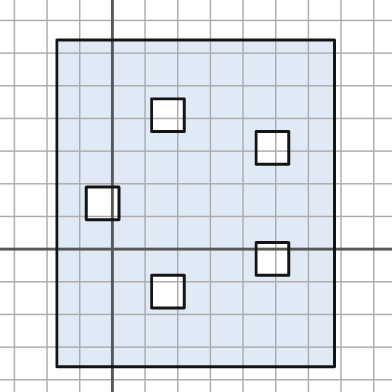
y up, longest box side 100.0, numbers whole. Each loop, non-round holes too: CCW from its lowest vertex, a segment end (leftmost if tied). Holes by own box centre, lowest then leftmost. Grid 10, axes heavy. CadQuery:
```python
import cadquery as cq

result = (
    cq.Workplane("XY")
    .moveTo(-17.0, -36.0)
    .lineTo(68.0, -36.0)
    .lineTo(68.0, 64.0)
    .lineTo(-17.0, 64.0)
    .close()
    .moveTo(12.0, -18.0)
    .lineTo(22.0, -18.0)
    .lineTo(22.0, -8.0)
    .lineTo(12.0, -8.0)
    .close()
    .moveTo(44.0, -8.0)
    .lineTo(54.0, -8.0)
    .lineTo(54.0, 2.0)
    .lineTo(44.0, 2.0)
    .close()
    .moveTo(-8.0, 9.0)
    .lineTo(2.0, 9.0)
    .lineTo(2.0, 19.0)
    .lineTo(-8.0, 19.0)
    .close()
    .moveTo(44.0, 26.0)
    .lineTo(54.0, 26.0)
    .lineTo(54.0, 36.0)
    .lineTo(44.0, 36.0)
    .close()
    .moveTo(12.0, 36.0)
    .lineTo(22.0, 36.0)
    .lineTo(22.0, 46.0)
    .lineTo(12.0, 46.0)
    .close()
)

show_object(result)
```